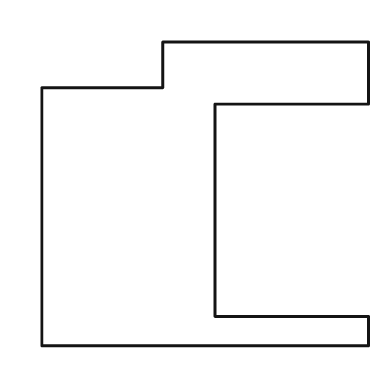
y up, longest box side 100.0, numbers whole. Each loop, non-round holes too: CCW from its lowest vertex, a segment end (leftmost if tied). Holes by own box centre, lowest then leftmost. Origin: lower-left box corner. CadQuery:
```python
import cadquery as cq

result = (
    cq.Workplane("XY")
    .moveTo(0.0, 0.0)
    .lineTo(100.0, 0.0)
    .lineTo(100.0, 9.0)
    .lineTo(53.0, 9.0)
    .lineTo(53.0, 74.0)
    .lineTo(100.0, 74.0)
    .lineTo(100.0, 93.0)
    .lineTo(37.0, 93.0)
    .lineTo(37.0, 79.0)
    .lineTo(0.0, 79.0)
    .close()
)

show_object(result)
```